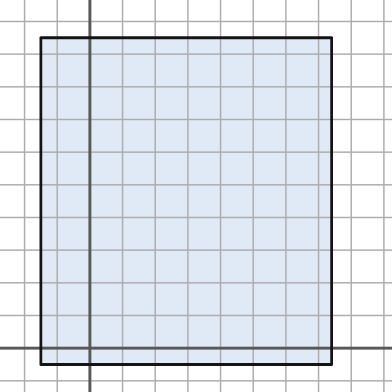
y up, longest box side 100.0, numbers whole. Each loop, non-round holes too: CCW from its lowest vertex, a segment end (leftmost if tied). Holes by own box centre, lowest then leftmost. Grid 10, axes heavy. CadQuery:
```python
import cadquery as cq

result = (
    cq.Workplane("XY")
    .moveTo(-15.0, -5.0)
    .lineTo(74.0, -5.0)
    .lineTo(74.0, 95.0)
    .lineTo(-15.0, 95.0)
    .close()
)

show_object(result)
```